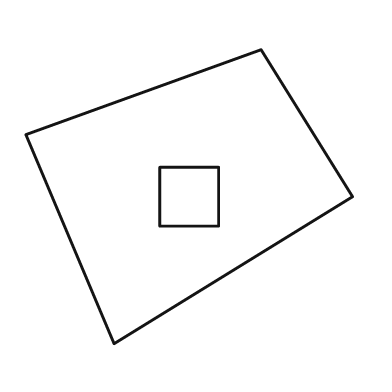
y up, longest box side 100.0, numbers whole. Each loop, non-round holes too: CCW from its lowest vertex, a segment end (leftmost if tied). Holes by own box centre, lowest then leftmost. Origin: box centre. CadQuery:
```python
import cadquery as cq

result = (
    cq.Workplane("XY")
    .moveTo(-23.0, -45.0)
    .lineTo(50.0, 0.0)
    .lineTo(22.0, 45.0)
    .lineTo(-50.0, 19.0)
    .close()
    .moveTo(-9.0, -9.0)
    .lineTo(9.0, -9.0)
    .lineTo(9.0, 9.0)
    .lineTo(-9.0, 9.0)
    .close()
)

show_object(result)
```